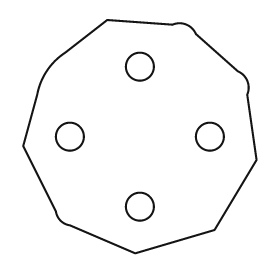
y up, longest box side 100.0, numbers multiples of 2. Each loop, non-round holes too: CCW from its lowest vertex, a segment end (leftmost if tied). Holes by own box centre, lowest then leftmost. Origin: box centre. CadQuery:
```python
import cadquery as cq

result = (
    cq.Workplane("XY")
    .moveTo(-2.0, -50.0)
    .lineTo(32.0, -40.0)
    .lineTo(50.0, -10.0)
    .lineTo(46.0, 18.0)
    .threePointArc((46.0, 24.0), (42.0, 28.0))
    .lineTo(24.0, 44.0)
    .threePointArc((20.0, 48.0), (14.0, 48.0))
    .lineTo(-14.0, 50.0)
    .lineTo(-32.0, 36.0)
    .threePointArc((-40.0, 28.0), (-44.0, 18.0))
    .lineTo(-50.0, -4.0)
    .lineTo(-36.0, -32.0)
    .threePointArc((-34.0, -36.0), (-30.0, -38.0))
    .close()
    .moveTo(0.0, -30.0)
    .circle(6.0)
    .moveTo(-30.0, 0.0)
    .circle(6.0)
    .moveTo(30.0, 0.0)
    .circle(6.0)
    .moveTo(0.0, 30.0)
    .circle(6.0)
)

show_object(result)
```